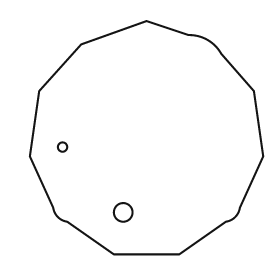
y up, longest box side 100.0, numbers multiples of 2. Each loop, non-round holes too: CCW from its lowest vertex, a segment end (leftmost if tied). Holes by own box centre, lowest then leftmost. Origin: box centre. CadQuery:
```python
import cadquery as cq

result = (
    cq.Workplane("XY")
    .moveTo(-14.0, -50.0)
    .lineTo(14.0, -50.0)
    .lineTo(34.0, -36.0)
    .threePointArc((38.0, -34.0), (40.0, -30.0))
    .lineTo(50.0, -8.0)
    .lineTo(46.0, 20.0)
    .lineTo(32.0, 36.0)
    .threePointArc((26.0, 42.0), (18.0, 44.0))
    .lineTo(0.0, 50.0)
    .lineTo(-28.0, 40.0)
    .lineTo(-46.0, 20.0)
    .lineTo(-50.0, -8.0)
    .lineTo(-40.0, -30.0)
    .threePointArc((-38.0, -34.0), (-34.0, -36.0))
    .close()
    .moveTo(-10.0, -32.0)
    .circle(4.0)
    .moveTo(-36.0, -4.0)
    .circle(2.0)
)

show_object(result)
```